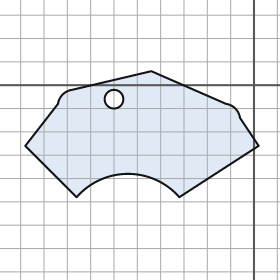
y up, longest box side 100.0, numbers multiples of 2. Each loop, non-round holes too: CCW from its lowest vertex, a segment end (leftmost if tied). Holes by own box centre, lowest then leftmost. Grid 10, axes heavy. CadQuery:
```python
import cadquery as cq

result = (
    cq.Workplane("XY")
    .moveTo(-76.0, -48.0)
    .threePointArc((-54.0, -38.0), (-32.0, -48.0))
    .lineTo(2.0, -26.0)
    .lineTo(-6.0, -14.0)
    .threePointArc((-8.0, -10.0), (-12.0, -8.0))
    .lineTo(-44.0, 6.0)
    .lineTo(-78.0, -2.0)
    .threePointArc((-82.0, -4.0), (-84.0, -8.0))
    .lineTo(-98.0, -26.0)
    .close()
    .moveTo(-60.0, -6.0)
    .circle(4.0)
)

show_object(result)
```